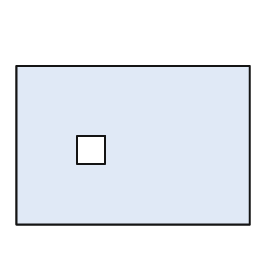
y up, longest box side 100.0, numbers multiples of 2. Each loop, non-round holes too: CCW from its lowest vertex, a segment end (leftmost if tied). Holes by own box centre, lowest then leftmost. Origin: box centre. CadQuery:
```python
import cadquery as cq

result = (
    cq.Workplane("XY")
    .moveTo(-50.0, -34.0)
    .lineTo(50.0, -34.0)
    .lineTo(50.0, 34.0)
    .lineTo(-50.0, 34.0)
    .close()
    .moveTo(-24.0, -8.0)
    .lineTo(-12.0, -8.0)
    .lineTo(-12.0, 4.0)
    .lineTo(-24.0, 4.0)
    .close()
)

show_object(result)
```